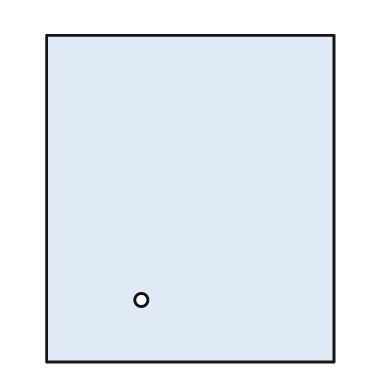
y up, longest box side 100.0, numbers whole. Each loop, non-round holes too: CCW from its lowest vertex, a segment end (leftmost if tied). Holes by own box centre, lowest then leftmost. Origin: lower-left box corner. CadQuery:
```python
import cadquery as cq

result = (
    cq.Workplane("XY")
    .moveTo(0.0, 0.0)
    .lineTo(88.0, 0.0)
    .lineTo(88.0, 100.0)
    .lineTo(0.0, 100.0)
    .close()
    .moveTo(29.0, 19.0)
    .circle(2.0)
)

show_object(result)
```